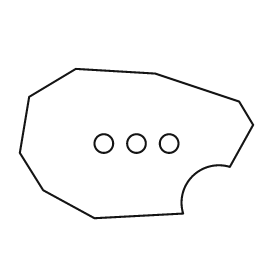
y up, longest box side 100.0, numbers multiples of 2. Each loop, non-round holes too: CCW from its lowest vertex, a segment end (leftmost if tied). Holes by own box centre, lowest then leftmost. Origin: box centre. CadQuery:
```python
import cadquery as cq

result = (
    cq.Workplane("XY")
    .moveTo(-18.0, -32.0)
    .lineTo(20.0, -30.0)
    .threePointArc((24.0, -14.0), (40.0, -10.0))
    .lineTo(50.0, 8.0)
    .lineTo(44.0, 18.0)
    .lineTo(8.0, 30.0)
    .lineTo(-26.0, 32.0)
    .lineTo(-46.0, 20.0)
    .lineTo(-50.0, -4.0)
    .lineTo(-40.0, -20.0)
    .close()
    .moveTo(-14.0, 0.0)
    .circle(4.0)
    .moveTo(0.0, 0.0)
    .circle(4.0)
    .moveTo(14.0, 0.0)
    .circle(4.0)
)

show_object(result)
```